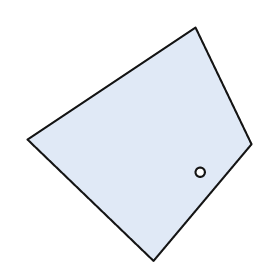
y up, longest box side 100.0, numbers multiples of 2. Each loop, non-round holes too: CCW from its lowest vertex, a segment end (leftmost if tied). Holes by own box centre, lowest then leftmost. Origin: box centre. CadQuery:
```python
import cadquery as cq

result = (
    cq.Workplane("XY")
    .moveTo(6.0, -50.0)
    .lineTo(48.0, 0.0)
    .lineTo(24.0, 50.0)
    .lineTo(-48.0, 2.0)
    .close()
    .moveTo(26.0, -12.0)
    .circle(2.0)
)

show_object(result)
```